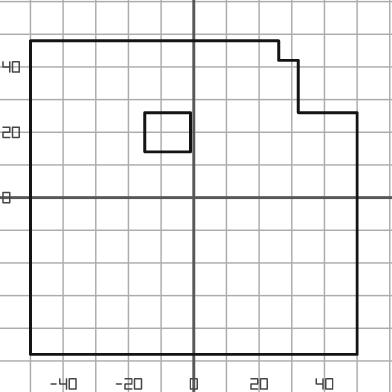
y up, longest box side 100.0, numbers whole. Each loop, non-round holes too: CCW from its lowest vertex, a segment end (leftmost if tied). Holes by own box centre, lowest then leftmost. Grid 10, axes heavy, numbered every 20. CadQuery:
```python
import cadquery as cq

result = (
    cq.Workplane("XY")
    .moveTo(-50.0, -48.0)
    .lineTo(50.0, -48.0)
    .lineTo(50.0, 26.0)
    .lineTo(32.0, 26.0)
    .lineTo(32.0, 42.0)
    .lineTo(26.0, 42.0)
    .lineTo(26.0, 48.0)
    .lineTo(-50.0, 48.0)
    .close()
    .moveTo(-15.0, 14.0)
    .lineTo(-1.0, 14.0)
    .lineTo(-1.0, 26.0)
    .lineTo(-15.0, 26.0)
    .close()
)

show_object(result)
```